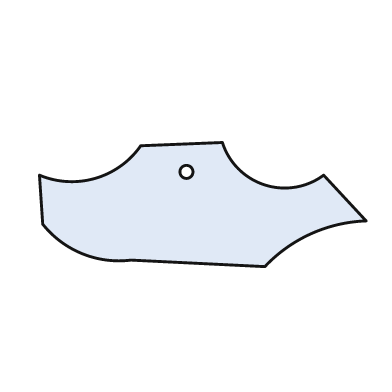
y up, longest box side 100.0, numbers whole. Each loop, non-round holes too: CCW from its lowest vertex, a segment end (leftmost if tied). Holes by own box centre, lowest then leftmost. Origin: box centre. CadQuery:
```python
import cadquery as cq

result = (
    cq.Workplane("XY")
    .moveTo(19.0, -19.0)
    .threePointArc((33.0, -9.0), (50.0, -5.0))
    .lineTo(37.0, 9.0)
    .threePointArc((19.0, 6.0), (6.0, 19.0))
    .lineTo(-19.0, 18.0)
    .threePointArc((-33.0, 8.0), (-50.0, 9.0))
    .lineTo(-49.0, -6.0)
    .threePointArc((-37.0, -15.0), (-22.0, -17.0))
    .close()
    .moveTo(-5.0, 10.0)
    .circle(2.0)
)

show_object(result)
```